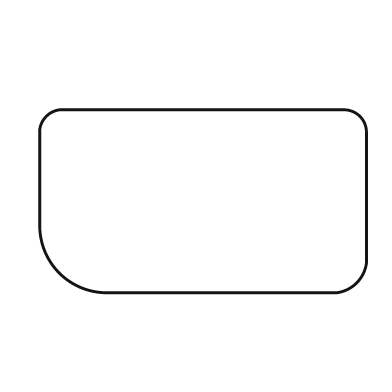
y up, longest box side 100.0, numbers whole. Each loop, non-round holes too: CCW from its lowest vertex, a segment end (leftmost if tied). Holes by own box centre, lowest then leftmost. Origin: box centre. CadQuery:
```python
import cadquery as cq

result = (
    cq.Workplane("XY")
    .moveTo(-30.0, -28.0)
    .lineTo(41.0, -28.0)
    .threePointArc((47.0, -25.0), (50.0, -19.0))
    .lineTo(50.0, 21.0)
    .threePointArc((48.0, 26.0), (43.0, 28.0))
    .lineTo(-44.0, 28.0)
    .threePointArc((-48.0, 26.0), (-50.0, 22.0))
    .lineTo(-50.0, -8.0)
    .threePointArc((-44.0, -22.0), (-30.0, -28.0))
    .close()
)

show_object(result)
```